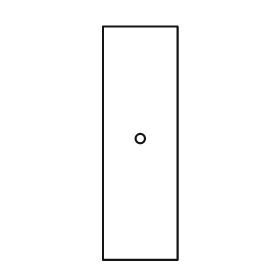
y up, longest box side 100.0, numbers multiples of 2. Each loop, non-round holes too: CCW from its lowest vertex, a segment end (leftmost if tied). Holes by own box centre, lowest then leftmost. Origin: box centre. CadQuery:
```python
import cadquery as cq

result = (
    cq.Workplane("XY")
    .moveTo(-16.0, -50.0)
    .lineTo(16.0, -50.0)
    .lineTo(16.0, 50.0)
    .lineTo(-16.0, 50.0)
    .close()
    .moveTo(0.0, 2.0)
    .circle(2.0)
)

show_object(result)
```